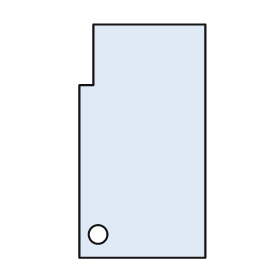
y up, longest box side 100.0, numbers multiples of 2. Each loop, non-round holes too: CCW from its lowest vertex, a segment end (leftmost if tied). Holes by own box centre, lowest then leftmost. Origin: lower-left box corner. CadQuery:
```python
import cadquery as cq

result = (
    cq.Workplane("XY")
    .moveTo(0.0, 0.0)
    .lineTo(54.0, 0.0)
    .lineTo(54.0, 100.0)
    .lineTo(6.0, 100.0)
    .lineTo(6.0, 74.0)
    .lineTo(0.0, 74.0)
    .close()
    .moveTo(8.0, 10.0)
    .circle(4.0)
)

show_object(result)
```